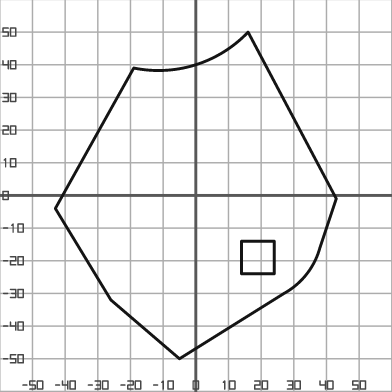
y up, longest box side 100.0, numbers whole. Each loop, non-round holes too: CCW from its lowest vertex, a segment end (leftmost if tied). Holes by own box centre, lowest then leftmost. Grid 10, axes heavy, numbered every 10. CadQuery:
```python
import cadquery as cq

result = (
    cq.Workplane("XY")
    .moveTo(-5.0, -50.0)
    .lineTo(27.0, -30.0)
    .threePointArc((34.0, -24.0), (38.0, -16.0))
    .lineTo(43.0, -1.0)
    .lineTo(16.0, 50.0)
    .threePointArc((0.0, 40.0), (-19.0, 39.0))
    .lineTo(-43.0, -4.0)
    .lineTo(-26.0, -32.0)
    .close()
    .moveTo(14.0, -24.0)
    .lineTo(24.0, -24.0)
    .lineTo(24.0, -14.0)
    .lineTo(14.0, -14.0)
    .close()
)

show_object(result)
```